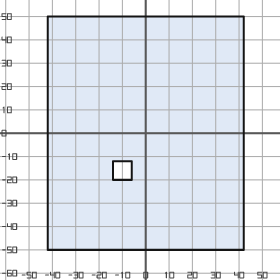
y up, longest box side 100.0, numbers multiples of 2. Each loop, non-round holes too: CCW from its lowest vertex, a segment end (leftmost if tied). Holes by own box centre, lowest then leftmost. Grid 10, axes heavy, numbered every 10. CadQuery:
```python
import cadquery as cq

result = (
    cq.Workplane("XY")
    .moveTo(-42.0, -50.0)
    .lineTo(42.0, -50.0)
    .lineTo(42.0, 50.0)
    .lineTo(-42.0, 50.0)
    .close()
    .moveTo(-14.0, -20.0)
    .lineTo(-6.0, -20.0)
    .lineTo(-6.0, -12.0)
    .lineTo(-14.0, -12.0)
    .close()
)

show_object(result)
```